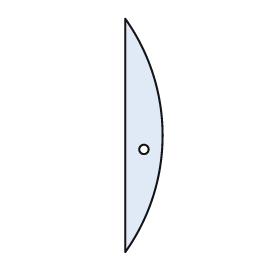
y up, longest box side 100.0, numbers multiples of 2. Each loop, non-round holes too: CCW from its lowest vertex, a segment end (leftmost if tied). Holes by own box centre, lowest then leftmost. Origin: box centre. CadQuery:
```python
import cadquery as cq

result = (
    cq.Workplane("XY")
    .moveTo(-8.0, -50.0)
    .threePointArc((8.0, 0.0), (-8.0, 50.0))
    .close()
    .moveTo(0.0, -6.0)
    .circle(2.0)
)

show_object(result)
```